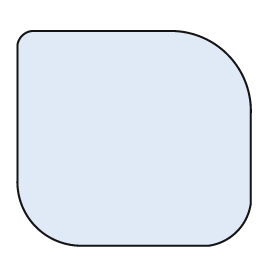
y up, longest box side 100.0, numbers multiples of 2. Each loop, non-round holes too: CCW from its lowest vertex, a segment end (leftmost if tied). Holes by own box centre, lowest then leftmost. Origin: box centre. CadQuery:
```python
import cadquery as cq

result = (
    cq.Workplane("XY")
    .moveTo(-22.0, -46.0)
    .lineTo(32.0, -46.0)
    .threePointArc((44.0, -40.0), (50.0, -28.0))
    .lineTo(50.0, 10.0)
    .threePointArc((40.0, 36.0), (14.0, 46.0))
    .lineTo(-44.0, 46.0)
    .threePointArc((-48.0, 44.0), (-50.0, 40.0))
    .lineTo(-50.0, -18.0)
    .threePointArc((-42.0, -38.0), (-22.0, -46.0))
    .close()
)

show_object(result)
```